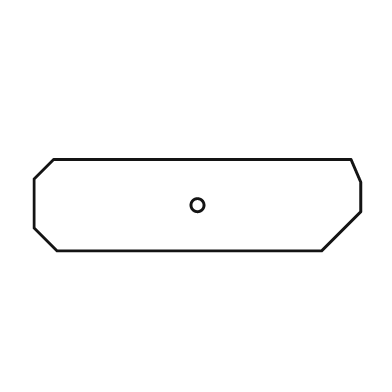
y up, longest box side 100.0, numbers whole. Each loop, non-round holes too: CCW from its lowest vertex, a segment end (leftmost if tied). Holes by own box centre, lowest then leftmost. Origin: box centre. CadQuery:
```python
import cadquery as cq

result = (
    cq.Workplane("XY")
    .moveTo(-43.0, -14.0)
    .lineTo(38.0, -14.0)
    .lineTo(50.0, -2.0)
    .lineTo(50.0, 7.0)
    .lineTo(47.0, 14.0)
    .lineTo(-44.0, 14.0)
    .lineTo(-50.0, 8.0)
    .lineTo(-50.0, -7.0)
    .close()
    .moveTo(0.0, 0.0)
    .circle(2.0)
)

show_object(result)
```